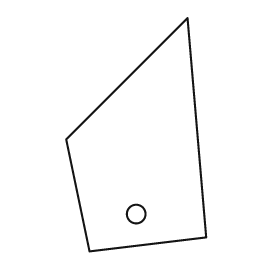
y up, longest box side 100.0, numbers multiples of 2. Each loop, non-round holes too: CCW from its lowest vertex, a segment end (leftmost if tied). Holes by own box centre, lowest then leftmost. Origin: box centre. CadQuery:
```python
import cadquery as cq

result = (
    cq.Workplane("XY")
    .moveTo(-20.0, -50.0)
    .lineTo(30.0, -44.0)
    .lineTo(22.0, 50.0)
    .lineTo(-30.0, -2.0)
    .close()
    .moveTo(0.0, -34.0)
    .circle(4.0)
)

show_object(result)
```